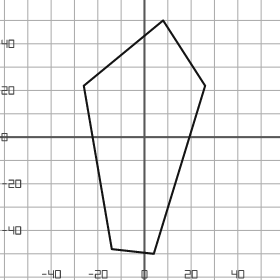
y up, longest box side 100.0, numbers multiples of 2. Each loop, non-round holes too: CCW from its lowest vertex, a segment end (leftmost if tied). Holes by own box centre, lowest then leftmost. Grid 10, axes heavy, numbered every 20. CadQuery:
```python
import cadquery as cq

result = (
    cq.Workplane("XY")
    .moveTo(4.0, -50.0)
    .lineTo(26.0, 22.0)
    .lineTo(8.0, 50.0)
    .lineTo(-26.0, 22.0)
    .lineTo(-14.0, -48.0)
    .close()
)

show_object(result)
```